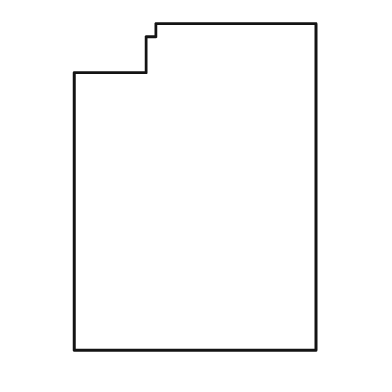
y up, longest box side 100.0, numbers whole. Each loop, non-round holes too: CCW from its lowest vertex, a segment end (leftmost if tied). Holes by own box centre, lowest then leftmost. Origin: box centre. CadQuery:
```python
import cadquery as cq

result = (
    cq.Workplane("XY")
    .moveTo(-37.0, -50.0)
    .lineTo(37.0, -50.0)
    .lineTo(37.0, 50.0)
    .lineTo(-12.0, 50.0)
    .lineTo(-12.0, 46.0)
    .lineTo(-15.0, 46.0)
    .lineTo(-15.0, 35.0)
    .lineTo(-37.0, 35.0)
    .close()
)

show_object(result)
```